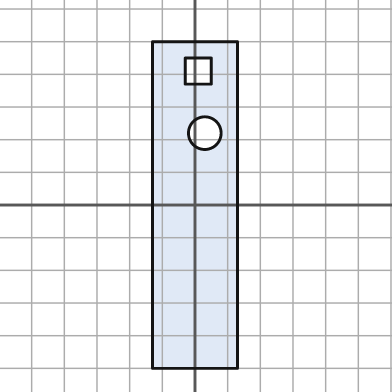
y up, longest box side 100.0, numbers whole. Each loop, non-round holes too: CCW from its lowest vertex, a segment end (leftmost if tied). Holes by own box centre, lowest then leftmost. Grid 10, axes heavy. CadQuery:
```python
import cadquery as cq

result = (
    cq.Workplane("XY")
    .moveTo(-13.0, -50.0)
    .lineTo(13.0, -50.0)
    .lineTo(13.0, 50.0)
    .lineTo(-13.0, 50.0)
    .close()
    .moveTo(3.0, 22.0)
    .circle(5.0)
    .moveTo(-3.0, 37.0)
    .lineTo(5.0, 37.0)
    .lineTo(5.0, 45.0)
    .lineTo(-3.0, 45.0)
    .close()
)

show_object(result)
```